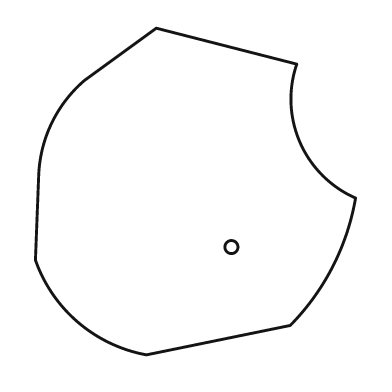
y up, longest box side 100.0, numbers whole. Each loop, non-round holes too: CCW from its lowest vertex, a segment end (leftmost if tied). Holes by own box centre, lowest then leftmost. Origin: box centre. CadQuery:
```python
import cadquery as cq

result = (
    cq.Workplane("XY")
    .moveTo(-15.0, -50.0)
    .lineTo(29.0, -41.0)
    .threePointArc((42.0, -23.0), (49.0, -2.0))
    .threePointArc((32.0, 15.0), (31.0, 39.0))
    .lineTo(-12.0, 50.0)
    .lineTo(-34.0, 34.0)
    .threePointArc((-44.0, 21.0), (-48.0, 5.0))
    .lineTo(-49.0, -21.0)
    .threePointArc((-36.0, -40.0), (-15.0, -50.0))
    .close()
    .moveTo(11.0, -17.0)
    .circle(2.0)
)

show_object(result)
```